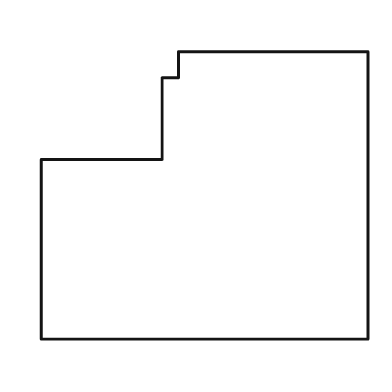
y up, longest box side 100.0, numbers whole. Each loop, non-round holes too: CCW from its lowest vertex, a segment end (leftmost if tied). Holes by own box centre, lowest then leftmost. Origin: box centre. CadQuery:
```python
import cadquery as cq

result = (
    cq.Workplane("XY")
    .moveTo(-50.0, -44.0)
    .lineTo(50.0, -44.0)
    .lineTo(50.0, 44.0)
    .lineTo(-8.0, 44.0)
    .lineTo(-8.0, 36.0)
    .lineTo(-13.0, 36.0)
    .lineTo(-13.0, 11.0)
    .lineTo(-50.0, 11.0)
    .close()
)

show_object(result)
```